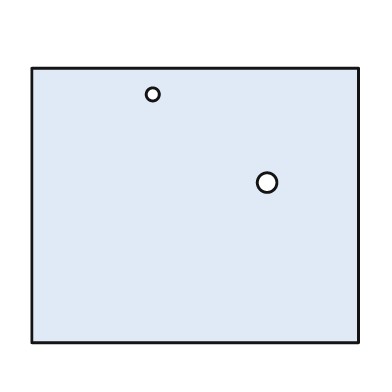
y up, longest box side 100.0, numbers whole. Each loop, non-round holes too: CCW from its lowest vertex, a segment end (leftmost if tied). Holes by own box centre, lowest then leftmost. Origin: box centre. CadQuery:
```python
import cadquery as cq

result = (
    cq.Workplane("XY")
    .moveTo(-50.0, -42.0)
    .lineTo(50.0, -42.0)
    .lineTo(50.0, 42.0)
    .lineTo(-50.0, 42.0)
    .close()
    .moveTo(22.0, 7.0)
    .circle(3.0)
    .moveTo(-13.0, 34.0)
    .circle(2.0)
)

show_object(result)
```